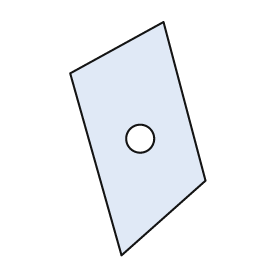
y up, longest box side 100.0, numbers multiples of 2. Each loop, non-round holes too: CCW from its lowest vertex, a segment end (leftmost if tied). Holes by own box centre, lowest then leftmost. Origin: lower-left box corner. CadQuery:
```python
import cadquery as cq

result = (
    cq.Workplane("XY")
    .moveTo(22.0, 0.0)
    .lineTo(58.0, 32.0)
    .lineTo(40.0, 100.0)
    .lineTo(0.0, 78.0)
    .close()
    .moveTo(30.0, 50.0)
    .circle(6.0)
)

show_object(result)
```